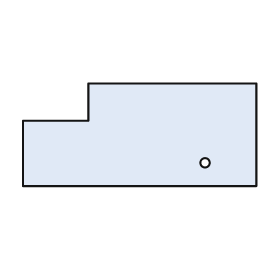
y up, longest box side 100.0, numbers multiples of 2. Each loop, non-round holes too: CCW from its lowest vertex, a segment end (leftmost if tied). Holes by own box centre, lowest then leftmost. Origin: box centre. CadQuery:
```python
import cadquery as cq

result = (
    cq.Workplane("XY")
    .moveTo(-50.0, -22.0)
    .lineTo(50.0, -22.0)
    .lineTo(50.0, 22.0)
    .lineTo(-22.0, 22.0)
    .lineTo(-22.0, 6.0)
    .lineTo(-50.0, 6.0)
    .close()
    .moveTo(28.0, -12.0)
    .circle(2.0)
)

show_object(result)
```